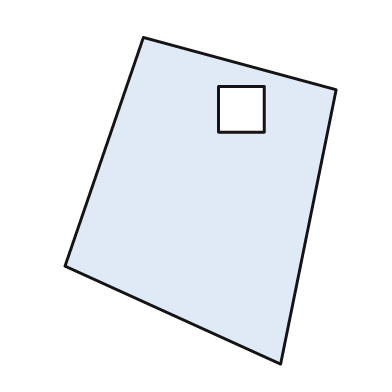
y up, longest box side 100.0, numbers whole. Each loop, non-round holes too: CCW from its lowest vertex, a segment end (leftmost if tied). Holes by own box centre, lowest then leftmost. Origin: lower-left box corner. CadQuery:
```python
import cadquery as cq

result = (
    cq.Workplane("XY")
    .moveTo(66.0, 0.0)
    .lineTo(83.0, 84.0)
    .lineTo(24.0, 100.0)
    .lineTo(0.0, 30.0)
    .close()
    .moveTo(47.0, 71.0)
    .lineTo(61.0, 71.0)
    .lineTo(61.0, 85.0)
    .lineTo(47.0, 85.0)
    .close()
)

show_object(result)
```